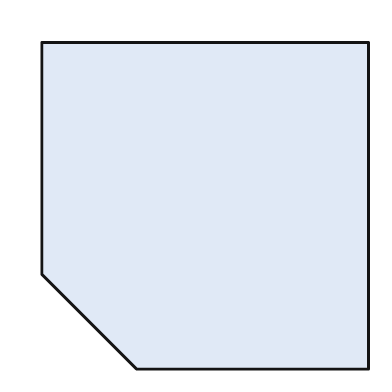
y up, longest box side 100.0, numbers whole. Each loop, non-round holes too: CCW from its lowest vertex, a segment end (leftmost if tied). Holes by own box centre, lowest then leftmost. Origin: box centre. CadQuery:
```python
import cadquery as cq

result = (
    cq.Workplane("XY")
    .moveTo(-21.0, -50.0)
    .lineTo(50.0, -50.0)
    .lineTo(50.0, 50.0)
    .lineTo(-50.0, 50.0)
    .lineTo(-50.0, -21.0)
    .close()
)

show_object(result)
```